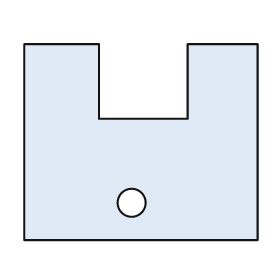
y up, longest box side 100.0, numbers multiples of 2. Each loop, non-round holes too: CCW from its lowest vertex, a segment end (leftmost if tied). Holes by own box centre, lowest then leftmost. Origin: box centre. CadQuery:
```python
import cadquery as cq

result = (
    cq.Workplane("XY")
    .moveTo(-50.0, -42.0)
    .lineTo(50.0, -42.0)
    .lineTo(50.0, 42.0)
    .lineTo(20.0, 42.0)
    .lineTo(20.0, 10.0)
    .lineTo(-18.0, 10.0)
    .lineTo(-18.0, 42.0)
    .lineTo(-50.0, 42.0)
    .close()
    .moveTo(-4.0, -26.0)
    .circle(6.0)
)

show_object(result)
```